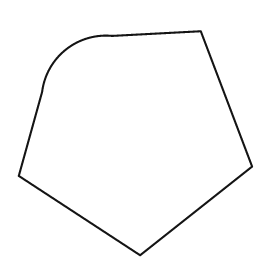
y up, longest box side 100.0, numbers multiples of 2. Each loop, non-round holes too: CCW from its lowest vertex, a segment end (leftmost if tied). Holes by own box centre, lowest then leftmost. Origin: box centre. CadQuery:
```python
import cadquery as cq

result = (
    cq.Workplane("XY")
    .moveTo(2.0, -48.0)
    .lineTo(50.0, -10.0)
    .lineTo(28.0, 48.0)
    .lineTo(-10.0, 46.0)
    .threePointArc((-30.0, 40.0), (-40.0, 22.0))
    .lineTo(-50.0, -14.0)
    .close()
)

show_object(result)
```